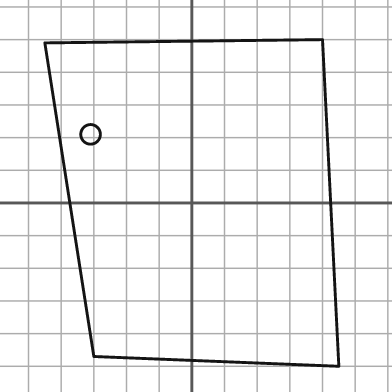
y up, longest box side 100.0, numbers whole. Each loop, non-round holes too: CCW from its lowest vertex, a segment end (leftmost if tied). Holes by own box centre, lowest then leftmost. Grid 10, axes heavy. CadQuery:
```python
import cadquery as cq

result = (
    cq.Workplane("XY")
    .moveTo(45.0, -50.0)
    .lineTo(40.0, 50.0)
    .lineTo(-45.0, 49.0)
    .lineTo(-30.0, -47.0)
    .close()
    .moveTo(-31.0, 21.0)
    .circle(3.0)
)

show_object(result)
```